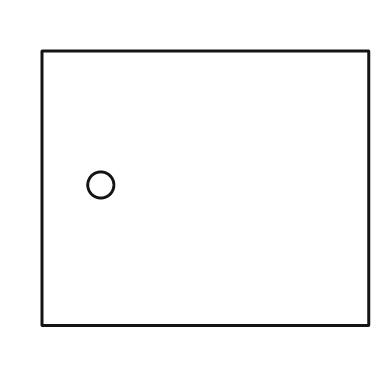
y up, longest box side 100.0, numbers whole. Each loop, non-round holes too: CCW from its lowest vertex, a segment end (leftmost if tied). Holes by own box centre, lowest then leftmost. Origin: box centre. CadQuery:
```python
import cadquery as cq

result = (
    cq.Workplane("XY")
    .moveTo(-50.0, -42.0)
    .lineTo(50.0, -42.0)
    .lineTo(50.0, 42.0)
    .lineTo(-50.0, 42.0)
    .close()
    .moveTo(-32.0, 1.0)
    .circle(4.0)
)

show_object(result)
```